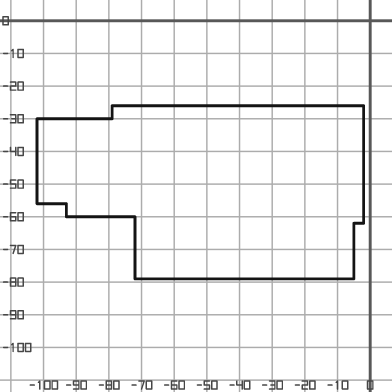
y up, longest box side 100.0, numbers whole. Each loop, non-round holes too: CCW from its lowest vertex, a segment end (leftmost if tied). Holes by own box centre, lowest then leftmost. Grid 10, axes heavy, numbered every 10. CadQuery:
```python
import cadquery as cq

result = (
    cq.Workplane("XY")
    .moveTo(-72.0, -79.0)
    .lineTo(-5.0, -79.0)
    .lineTo(-5.0, -62.0)
    .lineTo(-2.0, -62.0)
    .lineTo(-2.0, -26.0)
    .lineTo(-79.0, -26.0)
    .lineTo(-79.0, -30.0)
    .lineTo(-102.0, -30.0)
    .lineTo(-102.0, -56.0)
    .lineTo(-93.0, -56.0)
    .lineTo(-93.0, -60.0)
    .lineTo(-72.0, -60.0)
    .close()
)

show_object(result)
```